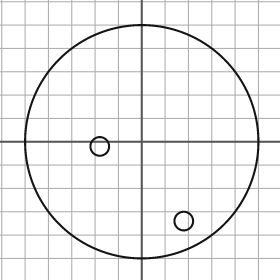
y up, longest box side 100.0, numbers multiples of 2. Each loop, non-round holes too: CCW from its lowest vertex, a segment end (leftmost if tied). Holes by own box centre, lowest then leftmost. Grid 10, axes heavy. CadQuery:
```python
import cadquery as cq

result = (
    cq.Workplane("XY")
    .moveTo(0.0, 0.0)
    .circle(50.0)
    .moveTo(18.0, -34.0)
    .circle(4.0)
    .moveTo(-18.0, -2.0)
    .circle(4.0)
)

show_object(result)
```